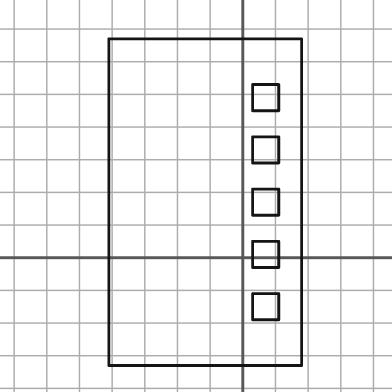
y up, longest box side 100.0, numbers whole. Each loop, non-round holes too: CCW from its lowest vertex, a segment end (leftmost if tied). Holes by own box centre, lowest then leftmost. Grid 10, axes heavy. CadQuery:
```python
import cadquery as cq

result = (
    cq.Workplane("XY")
    .moveTo(-41.0, -33.0)
    .lineTo(18.0, -33.0)
    .lineTo(18.0, 67.0)
    .lineTo(-41.0, 67.0)
    .close()
    .moveTo(3.0, -19.0)
    .lineTo(11.0, -19.0)
    .lineTo(11.0, -11.0)
    .lineTo(3.0, -11.0)
    .close()
    .moveTo(3.0, -3.0)
    .lineTo(11.0, -3.0)
    .lineTo(11.0, 5.0)
    .lineTo(3.0, 5.0)
    .close()
    .moveTo(3.0, 13.0)
    .lineTo(11.0, 13.0)
    .lineTo(11.0, 21.0)
    .lineTo(3.0, 21.0)
    .close()
    .moveTo(3.0, 29.0)
    .lineTo(11.0, 29.0)
    .lineTo(11.0, 37.0)
    .lineTo(3.0, 37.0)
    .close()
    .moveTo(3.0, 45.0)
    .lineTo(11.0, 45.0)
    .lineTo(11.0, 53.0)
    .lineTo(3.0, 53.0)
    .close()
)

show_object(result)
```